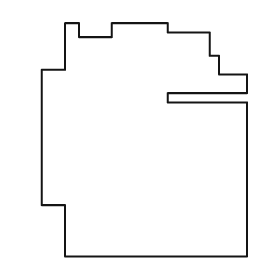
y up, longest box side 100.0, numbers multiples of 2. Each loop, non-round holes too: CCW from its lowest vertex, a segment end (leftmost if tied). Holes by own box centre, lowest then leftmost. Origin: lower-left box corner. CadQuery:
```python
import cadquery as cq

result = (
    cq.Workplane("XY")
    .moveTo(10.0, 0.0)
    .lineTo(88.0, 0.0)
    .lineTo(88.0, 66.0)
    .lineTo(54.0, 66.0)
    .lineTo(54.0, 70.0)
    .lineTo(88.0, 70.0)
    .lineTo(88.0, 78.0)
    .lineTo(76.0, 78.0)
    .lineTo(76.0, 86.0)
    .lineTo(72.0, 86.0)
    .lineTo(72.0, 96.0)
    .lineTo(54.0, 96.0)
    .lineTo(54.0, 100.0)
    .lineTo(30.0, 100.0)
    .lineTo(30.0, 94.0)
    .lineTo(16.0, 94.0)
    .lineTo(16.0, 100.0)
    .lineTo(10.0, 100.0)
    .lineTo(10.0, 80.0)
    .lineTo(0.0, 80.0)
    .lineTo(0.0, 22.0)
    .lineTo(10.0, 22.0)
    .close()
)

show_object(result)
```